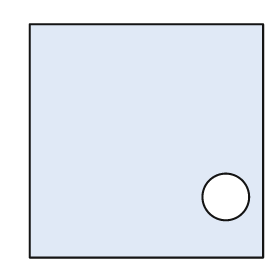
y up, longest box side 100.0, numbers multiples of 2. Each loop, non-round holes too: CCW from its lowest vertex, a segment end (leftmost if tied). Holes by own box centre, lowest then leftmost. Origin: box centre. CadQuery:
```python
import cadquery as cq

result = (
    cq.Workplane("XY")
    .moveTo(-50.0, -50.0)
    .lineTo(50.0, -50.0)
    .lineTo(50.0, 50.0)
    .lineTo(-50.0, 50.0)
    .close()
    .moveTo(34.0, -24.0)
    .circle(10.0)
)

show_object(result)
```